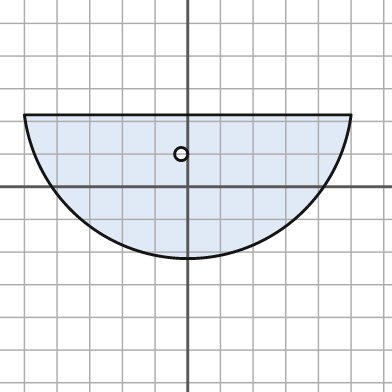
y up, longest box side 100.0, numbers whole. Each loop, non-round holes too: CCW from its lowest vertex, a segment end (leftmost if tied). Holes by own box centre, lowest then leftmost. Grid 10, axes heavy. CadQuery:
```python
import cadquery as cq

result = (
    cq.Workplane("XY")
    .moveTo(-50.0, 22.0)
    .threePointArc((0.0, -22.0), (50.0, 22.0))
    .close()
    .moveTo(-2.0, 10.0)
    .circle(2.0)
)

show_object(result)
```